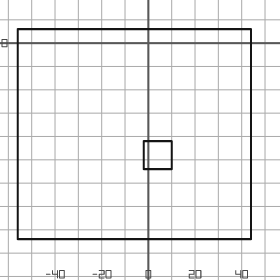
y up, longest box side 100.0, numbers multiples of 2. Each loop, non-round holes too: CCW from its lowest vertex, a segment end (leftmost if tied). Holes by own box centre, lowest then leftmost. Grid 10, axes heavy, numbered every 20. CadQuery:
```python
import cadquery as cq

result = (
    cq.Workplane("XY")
    .moveTo(-56.0, -84.0)
    .lineTo(44.0, -84.0)
    .lineTo(44.0, 6.0)
    .lineTo(-56.0, 6.0)
    .close()
    .moveTo(-2.0, -54.0)
    .lineTo(10.0, -54.0)
    .lineTo(10.0, -42.0)
    .lineTo(-2.0, -42.0)
    .close()
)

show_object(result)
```